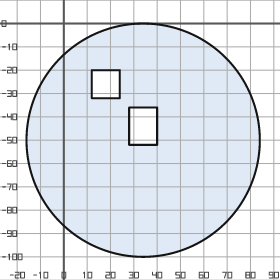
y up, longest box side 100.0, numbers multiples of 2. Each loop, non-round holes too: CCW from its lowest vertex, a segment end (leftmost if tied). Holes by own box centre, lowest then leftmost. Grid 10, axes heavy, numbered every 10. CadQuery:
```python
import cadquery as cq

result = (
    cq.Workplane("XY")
    .moveTo(34.0, -50.0)
    .circle(50.0)
    .moveTo(28.0, -52.0)
    .lineTo(40.0, -52.0)
    .lineTo(40.0, -36.0)
    .lineTo(28.0, -36.0)
    .close()
    .moveTo(12.0, -32.0)
    .lineTo(24.0, -32.0)
    .lineTo(24.0, -20.0)
    .lineTo(12.0, -20.0)
    .close()
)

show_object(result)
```